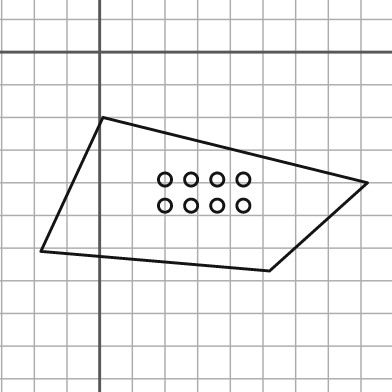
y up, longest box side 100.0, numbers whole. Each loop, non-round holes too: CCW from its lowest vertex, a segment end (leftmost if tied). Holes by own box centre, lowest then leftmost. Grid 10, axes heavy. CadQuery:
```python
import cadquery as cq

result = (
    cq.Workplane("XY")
    .moveTo(52.0, -67.0)
    .lineTo(82.0, -40.0)
    .lineTo(1.0, -20.0)
    .lineTo(-18.0, -61.0)
    .close()
    .moveTo(20.0, -47.0)
    .circle(2.0)
    .moveTo(28.0, -47.0)
    .circle(2.0)
    .moveTo(36.0, -47.0)
    .circle(2.0)
    .moveTo(44.0, -47.0)
    .circle(2.0)
    .moveTo(20.0, -39.0)
    .circle(2.0)
    .moveTo(28.0, -39.0)
    .circle(2.0)
    .moveTo(36.0, -39.0)
    .circle(2.0)
    .moveTo(44.0, -39.0)
    .circle(2.0)
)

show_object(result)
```